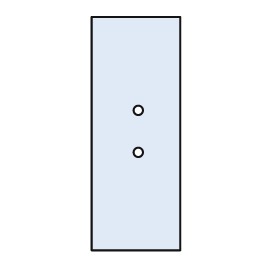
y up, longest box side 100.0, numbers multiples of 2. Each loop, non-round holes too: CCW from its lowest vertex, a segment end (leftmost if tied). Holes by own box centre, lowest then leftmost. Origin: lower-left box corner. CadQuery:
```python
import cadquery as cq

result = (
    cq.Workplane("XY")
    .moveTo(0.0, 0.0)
    .lineTo(38.0, 0.0)
    .lineTo(38.0, 100.0)
    .lineTo(0.0, 100.0)
    .close()
    .moveTo(20.0, 42.0)
    .circle(2.0)
    .moveTo(20.0, 60.0)
    .circle(2.0)
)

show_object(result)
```